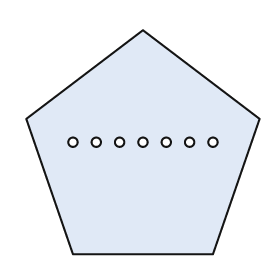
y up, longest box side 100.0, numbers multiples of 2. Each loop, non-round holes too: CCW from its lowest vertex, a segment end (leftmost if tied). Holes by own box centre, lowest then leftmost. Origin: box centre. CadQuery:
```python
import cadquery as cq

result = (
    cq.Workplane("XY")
    .moveTo(-30.0, -48.0)
    .lineTo(30.0, -48.0)
    .lineTo(50.0, 10.0)
    .lineTo(0.0, 48.0)
    .lineTo(-50.0, 10.0)
    .close()
    .moveTo(-30.0, 0.0)
    .circle(2.0)
    .moveTo(-20.0, 0.0)
    .circle(2.0)
    .moveTo(-10.0, 0.0)
    .circle(2.0)
    .moveTo(0.0, 0.0)
    .circle(2.0)
    .moveTo(10.0, 0.0)
    .circle(2.0)
    .moveTo(20.0, 0.0)
    .circle(2.0)
    .moveTo(30.0, 0.0)
    .circle(2.0)
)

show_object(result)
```